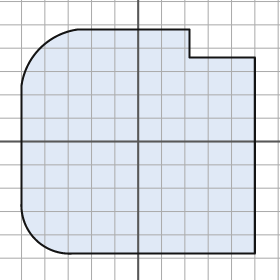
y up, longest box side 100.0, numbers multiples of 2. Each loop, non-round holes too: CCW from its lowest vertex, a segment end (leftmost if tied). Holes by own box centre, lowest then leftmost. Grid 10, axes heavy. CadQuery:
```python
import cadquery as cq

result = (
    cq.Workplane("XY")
    .moveTo(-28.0, -48.0)
    .lineTo(50.0, -48.0)
    .lineTo(50.0, 36.0)
    .lineTo(22.0, 36.0)
    .lineTo(22.0, 48.0)
    .lineTo(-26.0, 48.0)
    .threePointArc((-42.0, 40.0), (-50.0, 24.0))
    .lineTo(-50.0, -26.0)
    .threePointArc((-44.0, -42.0), (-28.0, -48.0))
    .close()
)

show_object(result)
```